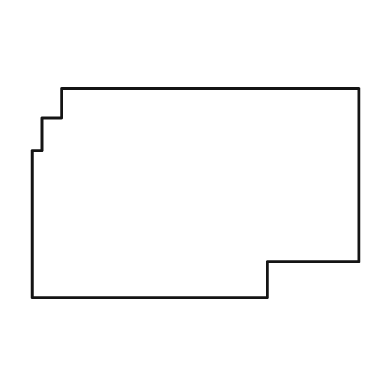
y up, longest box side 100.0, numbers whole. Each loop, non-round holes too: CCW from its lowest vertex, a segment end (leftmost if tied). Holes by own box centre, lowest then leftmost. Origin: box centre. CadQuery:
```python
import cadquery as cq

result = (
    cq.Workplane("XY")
    .moveTo(-50.0, -32.0)
    .lineTo(22.0, -32.0)
    .lineTo(22.0, -21.0)
    .lineTo(50.0, -21.0)
    .lineTo(50.0, 32.0)
    .lineTo(-41.0, 32.0)
    .lineTo(-41.0, 23.0)
    .lineTo(-47.0, 23.0)
    .lineTo(-47.0, 13.0)
    .lineTo(-50.0, 13.0)
    .close()
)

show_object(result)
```